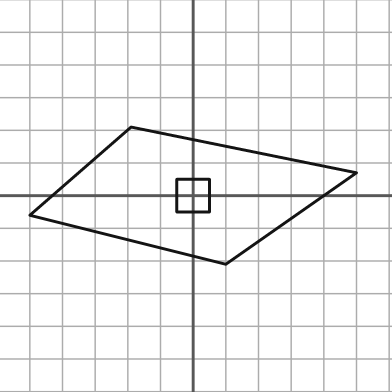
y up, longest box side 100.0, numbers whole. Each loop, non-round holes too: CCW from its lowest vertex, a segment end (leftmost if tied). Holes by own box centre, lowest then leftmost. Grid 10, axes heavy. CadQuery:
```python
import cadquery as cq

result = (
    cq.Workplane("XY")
    .moveTo(10.0, -21.0)
    .lineTo(50.0, 7.0)
    .lineTo(-19.0, 21.0)
    .lineTo(-50.0, -6.0)
    .close()
    .moveTo(-5.0, -5.0)
    .lineTo(5.0, -5.0)
    .lineTo(5.0, 5.0)
    .lineTo(-5.0, 5.0)
    .close()
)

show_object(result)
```